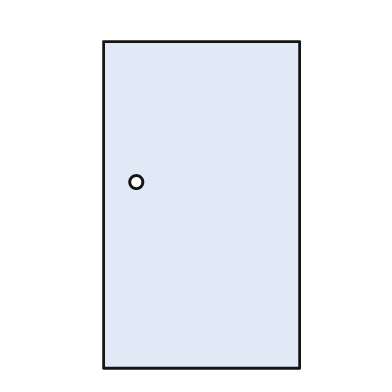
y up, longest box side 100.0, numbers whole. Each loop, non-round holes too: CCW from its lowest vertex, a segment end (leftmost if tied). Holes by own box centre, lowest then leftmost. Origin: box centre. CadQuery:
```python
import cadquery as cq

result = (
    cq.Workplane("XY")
    .moveTo(-30.0, -50.0)
    .lineTo(30.0, -50.0)
    .lineTo(30.0, 50.0)
    .lineTo(-30.0, 50.0)
    .close()
    .moveTo(-20.0, 7.0)
    .circle(2.0)
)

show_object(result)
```